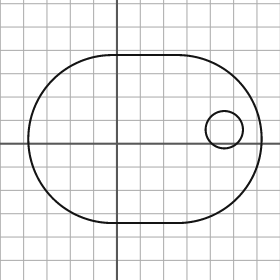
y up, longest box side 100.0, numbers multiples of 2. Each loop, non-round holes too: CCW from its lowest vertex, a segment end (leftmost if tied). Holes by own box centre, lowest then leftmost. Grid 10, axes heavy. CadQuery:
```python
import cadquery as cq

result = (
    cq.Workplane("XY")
    .moveTo(-2.0, -34.0)
    .lineTo(26.0, -34.0)
    .threePointArc((62.0, 2.0), (26.0, 38.0))
    .lineTo(-2.0, 38.0)
    .threePointArc((-38.0, 2.0), (-2.0, -34.0))
    .close()
    .moveTo(46.0, 6.0)
    .circle(8.0)
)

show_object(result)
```